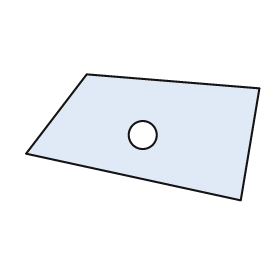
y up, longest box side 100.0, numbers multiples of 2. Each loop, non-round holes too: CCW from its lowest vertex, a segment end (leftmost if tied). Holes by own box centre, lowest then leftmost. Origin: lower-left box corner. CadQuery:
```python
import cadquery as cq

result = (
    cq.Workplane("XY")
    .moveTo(92.0, 0.0)
    .lineTo(100.0, 48.0)
    .lineTo(26.0, 54.0)
    .lineTo(0.0, 20.0)
    .close()
    .moveTo(50.0, 28.0)
    .circle(6.0)
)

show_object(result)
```